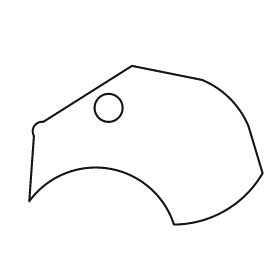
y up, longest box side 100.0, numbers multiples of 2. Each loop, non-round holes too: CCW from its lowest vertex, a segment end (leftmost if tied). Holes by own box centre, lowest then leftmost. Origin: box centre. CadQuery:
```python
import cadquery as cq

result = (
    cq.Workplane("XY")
    .moveTo(12.0, -34.0)
    .threePointArc((34.0, -28.0), (50.0, -12.0))
    .lineTo(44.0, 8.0)
    .threePointArc((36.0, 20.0), (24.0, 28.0))
    .lineTo(-6.0, 34.0)
    .lineTo(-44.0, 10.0)
    .threePointArc((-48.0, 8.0), (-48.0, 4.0))
    .lineTo(-50.0, -24.0)
    .threePointArc((-16.0, -10.0), (12.0, -34.0))
    .close()
    .moveTo(-16.0, 16.0)
    .circle(6.0)
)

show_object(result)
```